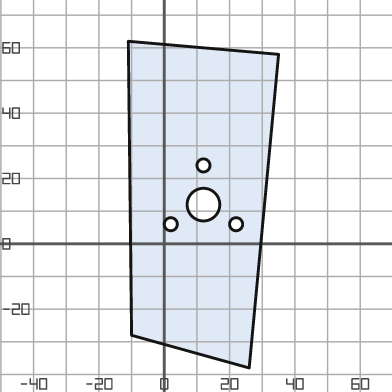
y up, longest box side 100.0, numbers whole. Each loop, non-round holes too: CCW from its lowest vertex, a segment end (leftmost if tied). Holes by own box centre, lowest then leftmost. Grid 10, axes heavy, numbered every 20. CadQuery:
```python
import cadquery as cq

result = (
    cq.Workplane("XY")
    .moveTo(26.0, -38.0)
    .lineTo(35.0, 58.0)
    .lineTo(-11.0, 62.0)
    .lineTo(-10.0, -28.0)
    .close()
    .moveTo(2.0, 6.0)
    .circle(2.0)
    .moveTo(22.0, 6.0)
    .circle(2.0)
    .moveTo(12.0, 12.0)
    .circle(5.0)
    .moveTo(12.0, 24.0)
    .circle(2.0)
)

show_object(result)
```